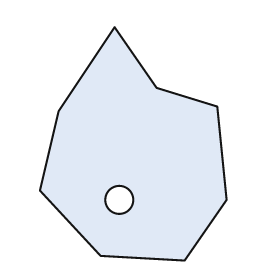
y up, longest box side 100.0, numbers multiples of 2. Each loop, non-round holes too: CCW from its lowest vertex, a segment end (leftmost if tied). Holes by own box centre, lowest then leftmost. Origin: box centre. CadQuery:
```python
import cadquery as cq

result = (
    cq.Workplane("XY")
    .moveTo(22.0, -50.0)
    .lineTo(40.0, -24.0)
    .lineTo(36.0, 16.0)
    .lineTo(10.0, 24.0)
    .lineTo(-8.0, 50.0)
    .lineTo(-32.0, 14.0)
    .lineTo(-40.0, -20.0)
    .lineTo(-14.0, -48.0)
    .close()
    .moveTo(-6.0, -24.0)
    .circle(6.0)
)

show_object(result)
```